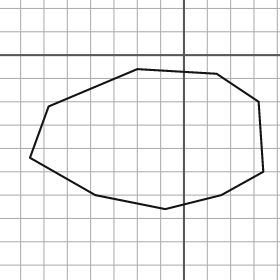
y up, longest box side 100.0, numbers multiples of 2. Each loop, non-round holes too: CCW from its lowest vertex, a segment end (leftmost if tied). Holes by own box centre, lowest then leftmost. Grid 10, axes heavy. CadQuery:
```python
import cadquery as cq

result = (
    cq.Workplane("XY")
    .moveTo(-8.0, -66.0)
    .lineTo(16.0, -60.0)
    .lineTo(34.0, -50.0)
    .lineTo(32.0, -20.0)
    .lineTo(14.0, -8.0)
    .lineTo(-20.0, -6.0)
    .lineTo(-58.0, -22.0)
    .lineTo(-66.0, -44.0)
    .lineTo(-38.0, -60.0)
    .close()
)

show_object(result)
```